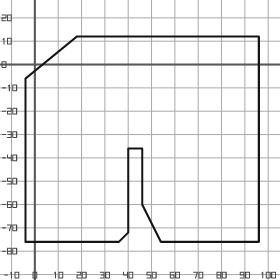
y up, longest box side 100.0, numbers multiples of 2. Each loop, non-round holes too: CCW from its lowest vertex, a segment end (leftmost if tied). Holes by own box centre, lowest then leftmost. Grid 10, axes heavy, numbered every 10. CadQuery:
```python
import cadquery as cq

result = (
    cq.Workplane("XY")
    .moveTo(-4.0, -76.0)
    .lineTo(36.0, -76.0)
    .lineTo(40.0, -72.0)
    .lineTo(40.0, -36.0)
    .lineTo(46.0, -36.0)
    .lineTo(46.0, -60.0)
    .lineTo(54.0, -76.0)
    .lineTo(96.0, -76.0)
    .lineTo(96.0, 12.0)
    .lineTo(18.0, 12.0)
    .lineTo(-4.0, -6.0)
    .close()
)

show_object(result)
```